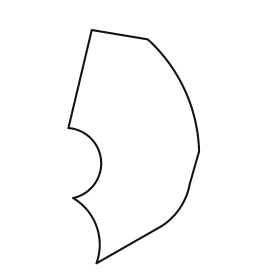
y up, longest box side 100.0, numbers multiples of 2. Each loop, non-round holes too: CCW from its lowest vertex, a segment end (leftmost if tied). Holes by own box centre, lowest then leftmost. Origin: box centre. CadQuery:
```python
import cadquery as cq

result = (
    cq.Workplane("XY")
    .moveTo(-16.0, -50.0)
    .lineTo(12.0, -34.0)
    .threePointArc((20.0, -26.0), (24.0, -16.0))
    .lineTo(28.0, -2.0)
    .threePointArc((22.0, 24.0), (6.0, 46.0))
    .lineTo(-18.0, 50.0)
    .lineTo(-28.0, 8.0)
    .threePointArc((-14.0, -6.0), (-26.0, -22.0))
    .threePointArc((-16.0, -34.0), (-16.0, -50.0))
    .close()
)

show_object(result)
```